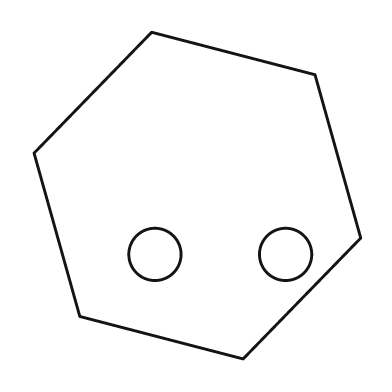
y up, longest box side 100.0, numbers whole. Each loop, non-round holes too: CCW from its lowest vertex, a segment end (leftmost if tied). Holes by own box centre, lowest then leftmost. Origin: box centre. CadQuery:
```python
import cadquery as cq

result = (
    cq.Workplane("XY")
    .moveTo(14.0, -50.0)
    .lineTo(50.0, -13.0)
    .lineTo(36.0, 37.0)
    .lineTo(-14.0, 50.0)
    .lineTo(-50.0, 13.0)
    .lineTo(-36.0, -37.0)
    .close()
    .moveTo(-13.0, -18.0)
    .circle(8.0)
    .moveTo(27.0, -18.0)
    .circle(8.0)
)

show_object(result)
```